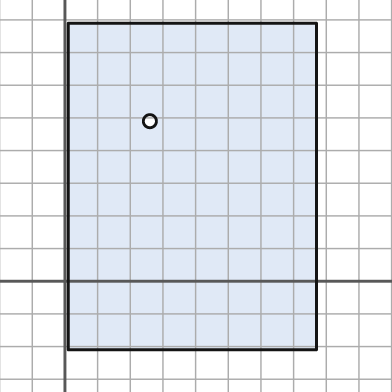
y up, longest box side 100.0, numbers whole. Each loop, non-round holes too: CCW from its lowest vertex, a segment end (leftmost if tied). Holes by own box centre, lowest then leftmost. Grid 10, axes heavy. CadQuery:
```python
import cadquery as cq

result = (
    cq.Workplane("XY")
    .moveTo(1.0, -21.0)
    .lineTo(77.0, -21.0)
    .lineTo(77.0, 79.0)
    .lineTo(1.0, 79.0)
    .close()
    .moveTo(26.0, 49.0)
    .circle(2.0)
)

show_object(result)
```